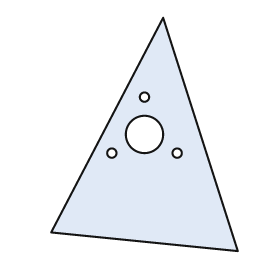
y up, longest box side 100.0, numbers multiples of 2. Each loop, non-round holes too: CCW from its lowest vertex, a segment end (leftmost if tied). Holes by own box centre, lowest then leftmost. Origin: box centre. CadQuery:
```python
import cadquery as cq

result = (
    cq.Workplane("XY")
    .moveTo(40.0, -50.0)
    .lineTo(8.0, 50.0)
    .lineTo(-40.0, -42.0)
    .close()
    .moveTo(-14.0, -8.0)
    .circle(2.0)
    .moveTo(14.0, -8.0)
    .circle(2.0)
    .moveTo(0.0, 0.0)
    .circle(8.0)
    .moveTo(0.0, 16.0)
    .circle(2.0)
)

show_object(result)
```